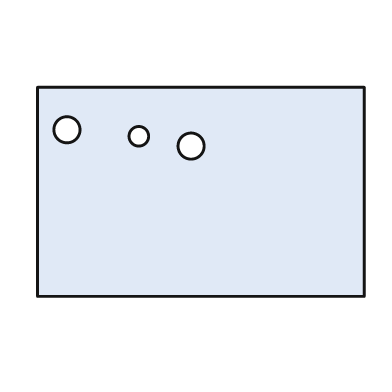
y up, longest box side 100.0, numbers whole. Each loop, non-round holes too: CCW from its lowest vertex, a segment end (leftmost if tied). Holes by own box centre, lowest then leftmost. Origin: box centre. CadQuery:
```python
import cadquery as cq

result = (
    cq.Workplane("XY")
    .moveTo(-50.0, -32.0)
    .lineTo(50.0, -32.0)
    .lineTo(50.0, 32.0)
    .lineTo(-50.0, 32.0)
    .close()
    .moveTo(-3.0, 14.0)
    .circle(4.0)
    .moveTo(-19.0, 17.0)
    .circle(3.0)
    .moveTo(-41.0, 19.0)
    .circle(4.0)
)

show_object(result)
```